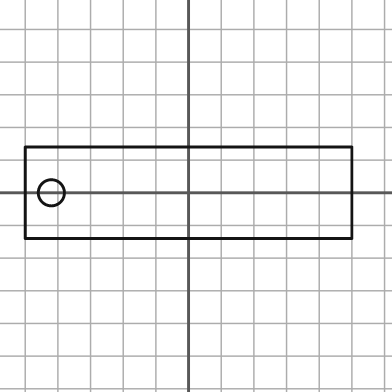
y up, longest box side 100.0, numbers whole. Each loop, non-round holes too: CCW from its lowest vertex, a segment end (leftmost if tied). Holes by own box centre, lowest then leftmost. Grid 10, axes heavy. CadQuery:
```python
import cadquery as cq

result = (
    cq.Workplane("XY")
    .moveTo(-50.0, -14.0)
    .lineTo(50.0, -14.0)
    .lineTo(50.0, 14.0)
    .lineTo(-50.0, 14.0)
    .close()
    .moveTo(-42.0, 0.0)
    .circle(4.0)
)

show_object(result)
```